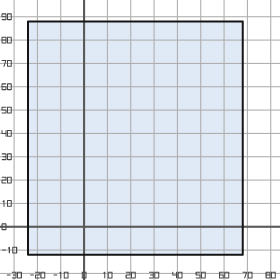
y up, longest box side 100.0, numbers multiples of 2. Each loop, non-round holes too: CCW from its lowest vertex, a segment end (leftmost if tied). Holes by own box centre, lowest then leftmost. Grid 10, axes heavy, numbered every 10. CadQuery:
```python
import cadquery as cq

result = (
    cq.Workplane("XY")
    .moveTo(-24.0, -12.0)
    .lineTo(68.0, -12.0)
    .lineTo(68.0, 88.0)
    .lineTo(-24.0, 88.0)
    .close()
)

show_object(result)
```